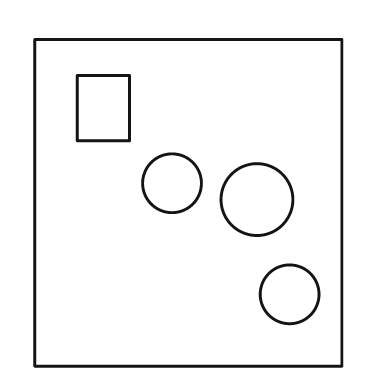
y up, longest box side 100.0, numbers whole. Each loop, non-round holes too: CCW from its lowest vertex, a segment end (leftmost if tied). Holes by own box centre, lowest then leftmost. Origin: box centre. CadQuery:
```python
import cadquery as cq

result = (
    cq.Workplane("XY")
    .moveTo(-47.0, -50.0)
    .lineTo(47.0, -50.0)
    .lineTo(47.0, 50.0)
    .lineTo(-47.0, 50.0)
    .close()
    .moveTo(31.0, -28.0)
    .circle(9.0)
    .moveTo(21.0, 1.0)
    .circle(11.0)
    .moveTo(-5.0, 6.0)
    .circle(9.0)
    .moveTo(-34.0, 19.0)
    .lineTo(-18.0, 19.0)
    .lineTo(-18.0, 39.0)
    .lineTo(-34.0, 39.0)
    .close()
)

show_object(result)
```